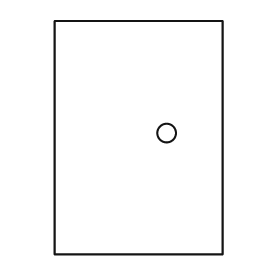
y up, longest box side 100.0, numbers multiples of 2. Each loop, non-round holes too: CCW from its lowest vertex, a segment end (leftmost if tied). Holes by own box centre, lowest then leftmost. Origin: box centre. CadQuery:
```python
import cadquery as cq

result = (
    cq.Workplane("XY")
    .moveTo(-36.0, -50.0)
    .lineTo(36.0, -50.0)
    .lineTo(36.0, 50.0)
    .lineTo(-36.0, 50.0)
    .close()
    .moveTo(12.0, 2.0)
    .circle(4.0)
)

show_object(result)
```